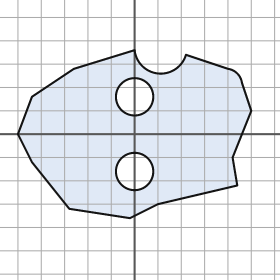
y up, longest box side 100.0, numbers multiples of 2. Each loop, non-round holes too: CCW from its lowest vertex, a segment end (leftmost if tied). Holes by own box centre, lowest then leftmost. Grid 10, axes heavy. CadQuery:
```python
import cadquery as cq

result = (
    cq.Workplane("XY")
    .moveTo(-2.0, -36.0)
    .lineTo(10.0, -30.0)
    .lineTo(44.0, -22.0)
    .lineTo(42.0, -10.0)
    .lineTo(50.0, 10.0)
    .lineTo(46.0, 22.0)
    .threePointArc((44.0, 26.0), (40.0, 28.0))
    .lineTo(22.0, 34.0)
    .threePointArc((10.0, 26.0), (0.0, 36.0))
    .lineTo(-26.0, 28.0)
    .lineTo(-44.0, 16.0)
    .lineTo(-50.0, 0.0)
    .lineTo(-44.0, -12.0)
    .lineTo(-28.0, -32.0)
    .close()
    .moveTo(0.0, -16.0)
    .circle(8.0)
    .moveTo(0.0, 16.0)
    .circle(8.0)
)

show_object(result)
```